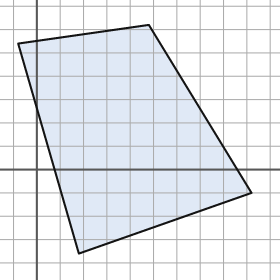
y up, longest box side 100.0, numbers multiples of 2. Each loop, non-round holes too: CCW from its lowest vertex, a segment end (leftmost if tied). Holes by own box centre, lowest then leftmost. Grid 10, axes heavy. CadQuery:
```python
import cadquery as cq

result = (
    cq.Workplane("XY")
    .moveTo(18.0, -36.0)
    .lineTo(92.0, -10.0)
    .lineTo(48.0, 62.0)
    .lineTo(-8.0, 54.0)
    .close()
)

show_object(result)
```